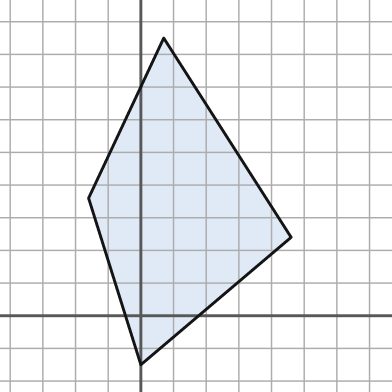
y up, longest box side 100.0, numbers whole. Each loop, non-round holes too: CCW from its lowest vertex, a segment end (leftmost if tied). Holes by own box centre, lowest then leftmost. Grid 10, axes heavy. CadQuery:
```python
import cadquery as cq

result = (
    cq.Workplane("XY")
    .moveTo(0.0, -15.0)
    .lineTo(46.0, 24.0)
    .lineTo(7.0, 85.0)
    .lineTo(-16.0, 36.0)
    .close()
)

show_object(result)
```